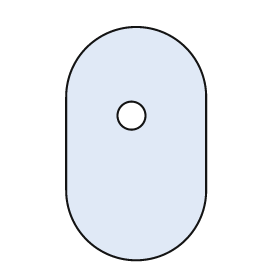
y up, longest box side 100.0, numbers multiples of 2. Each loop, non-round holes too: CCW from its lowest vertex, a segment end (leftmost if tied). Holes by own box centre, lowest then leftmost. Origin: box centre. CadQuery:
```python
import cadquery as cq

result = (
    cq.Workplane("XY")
    .moveTo(-30.0, -20.0)
    .threePointArc((0.0, -50.0), (30.0, -20.0))
    .lineTo(30.0, 20.0)
    .threePointArc((0.0, 50.0), (-30.0, 20.0))
    .close()
    .moveTo(-2.0, 12.0)
    .circle(6.0)
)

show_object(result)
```